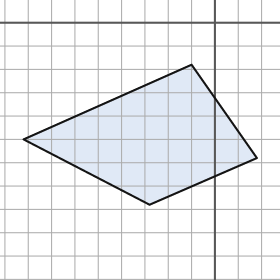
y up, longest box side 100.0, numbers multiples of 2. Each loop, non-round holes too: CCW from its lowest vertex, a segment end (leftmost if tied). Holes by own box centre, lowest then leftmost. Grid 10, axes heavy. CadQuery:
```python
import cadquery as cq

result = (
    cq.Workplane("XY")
    .moveTo(-28.0, -78.0)
    .lineTo(18.0, -58.0)
    .lineTo(-10.0, -18.0)
    .lineTo(-82.0, -50.0)
    .close()
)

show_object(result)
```